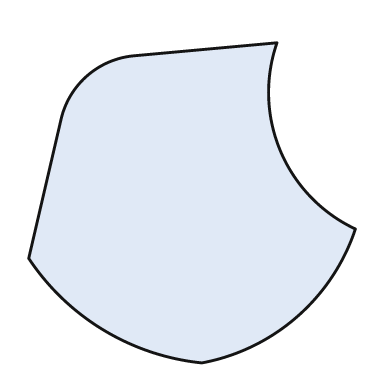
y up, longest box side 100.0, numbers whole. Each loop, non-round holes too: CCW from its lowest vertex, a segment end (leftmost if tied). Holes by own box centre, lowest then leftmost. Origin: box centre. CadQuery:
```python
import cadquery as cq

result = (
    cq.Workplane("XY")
    .moveTo(3.0, -49.0)
    .threePointArc((32.0, -35.0), (50.0, -8.0))
    .threePointArc((27.0, 16.0), (26.0, 49.0))
    .lineTo(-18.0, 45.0)
    .threePointArc((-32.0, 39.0), (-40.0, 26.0))
    .lineTo(-50.0, -17.0)
    .threePointArc((-27.0, -39.0), (3.0, -49.0))
    .close()
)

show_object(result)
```